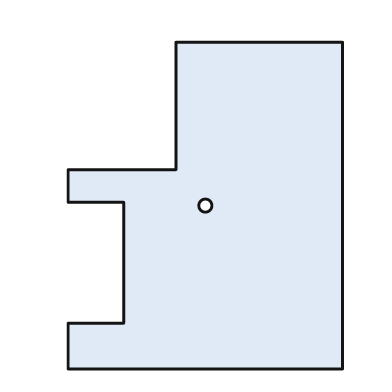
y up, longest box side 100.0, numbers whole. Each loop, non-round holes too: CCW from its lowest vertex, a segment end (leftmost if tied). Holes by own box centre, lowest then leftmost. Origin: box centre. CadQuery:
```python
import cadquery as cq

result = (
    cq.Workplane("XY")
    .moveTo(-42.0, -50.0)
    .lineTo(42.0, -50.0)
    .lineTo(42.0, 50.0)
    .lineTo(-9.0, 50.0)
    .lineTo(-9.0, 11.0)
    .lineTo(-42.0, 11.0)
    .lineTo(-42.0, 1.0)
    .lineTo(-25.0, 1.0)
    .lineTo(-25.0, -36.0)
    .lineTo(-42.0, -36.0)
    .close()
    .moveTo(0.0, 0.0)
    .circle(2.0)
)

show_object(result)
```